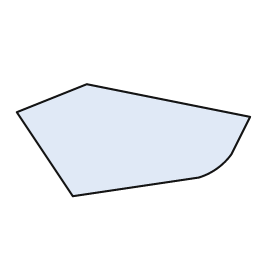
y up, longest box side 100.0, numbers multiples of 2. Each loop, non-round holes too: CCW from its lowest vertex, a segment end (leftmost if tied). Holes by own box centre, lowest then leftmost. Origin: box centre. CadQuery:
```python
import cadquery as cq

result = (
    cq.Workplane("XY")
    .moveTo(-26.0, -24.0)
    .lineTo(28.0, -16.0)
    .threePointArc((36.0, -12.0), (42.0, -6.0))
    .lineTo(50.0, 10.0)
    .lineTo(-20.0, 24.0)
    .lineTo(-50.0, 12.0)
    .close()
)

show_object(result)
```